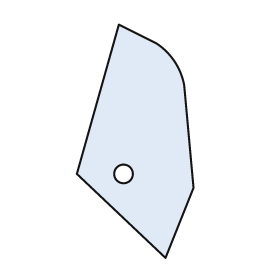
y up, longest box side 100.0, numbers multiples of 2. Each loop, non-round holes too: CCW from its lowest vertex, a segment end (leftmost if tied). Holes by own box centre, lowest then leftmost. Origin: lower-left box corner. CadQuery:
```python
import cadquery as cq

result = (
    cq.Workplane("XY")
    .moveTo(38.0, 0.0)
    .lineTo(50.0, 30.0)
    .lineTo(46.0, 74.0)
    .threePointArc((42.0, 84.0), (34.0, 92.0))
    .lineTo(18.0, 100.0)
    .lineTo(0.0, 36.0)
    .close()
    .moveTo(20.0, 36.0)
    .circle(4.0)
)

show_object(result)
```